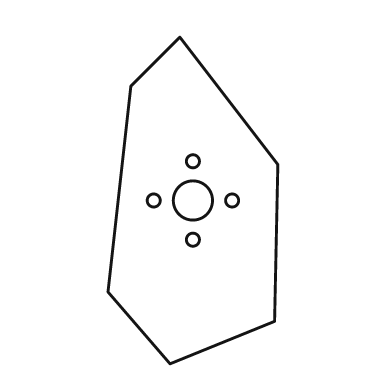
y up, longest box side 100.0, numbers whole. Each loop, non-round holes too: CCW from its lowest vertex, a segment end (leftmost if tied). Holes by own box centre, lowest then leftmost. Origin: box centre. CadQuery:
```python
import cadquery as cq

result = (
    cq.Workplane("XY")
    .moveTo(-7.0, -50.0)
    .lineTo(25.0, -37.0)
    .lineTo(26.0, 11.0)
    .lineTo(-4.0, 50.0)
    .lineTo(-19.0, 35.0)
    .lineTo(-26.0, -28.0)
    .close()
    .moveTo(0.0, -12.0)
    .circle(2.0)
    .moveTo(-12.0, 0.0)
    .circle(2.0)
    .moveTo(0.0, 0.0)
    .circle(6.0)
    .moveTo(12.0, 0.0)
    .circle(2.0)
    .moveTo(0.0, 12.0)
    .circle(2.0)
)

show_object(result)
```